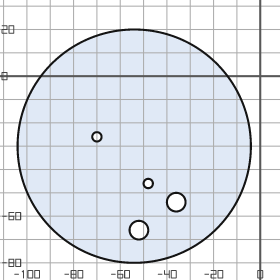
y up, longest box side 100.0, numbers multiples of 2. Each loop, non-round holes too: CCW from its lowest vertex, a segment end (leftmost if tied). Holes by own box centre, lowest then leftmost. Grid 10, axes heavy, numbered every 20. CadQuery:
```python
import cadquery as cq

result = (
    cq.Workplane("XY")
    .moveTo(-54.0, -30.0)
    .circle(50.0)
    .moveTo(-52.0, -66.0)
    .circle(4.0)
    .moveTo(-36.0, -54.0)
    .circle(4.0)
    .moveTo(-48.0, -46.0)
    .circle(2.0)
    .moveTo(-70.0, -26.0)
    .circle(2.0)
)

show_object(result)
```